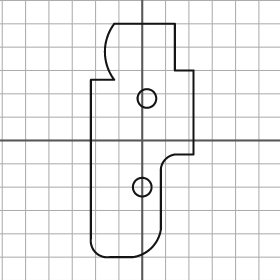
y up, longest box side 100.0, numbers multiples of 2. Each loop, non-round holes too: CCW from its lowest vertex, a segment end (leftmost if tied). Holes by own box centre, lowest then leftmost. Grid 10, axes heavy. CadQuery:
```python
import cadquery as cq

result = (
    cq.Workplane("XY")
    .moveTo(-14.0, -50.0)
    .lineTo(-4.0, -50.0)
    .threePointArc((4.0, -46.0), (8.0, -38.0))
    .lineTo(8.0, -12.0)
    .threePointArc((10.0, -8.0), (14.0, -6.0))
    .lineTo(22.0, -6.0)
    .lineTo(22.0, 30.0)
    .lineTo(14.0, 30.0)
    .lineTo(14.0, 50.0)
    .lineTo(-12.0, 50.0)
    .threePointArc((-16.0, 38.0), (-12.0, 26.0))
    .lineTo(-22.0, 26.0)
    .lineTo(-22.0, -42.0)
    .threePointArc((-20.0, -48.0), (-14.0, -50.0))
    .close()
    .moveTo(0.0, -20.0)
    .circle(4.0)
    .moveTo(2.0, 18.0)
    .circle(4.0)
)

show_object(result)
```